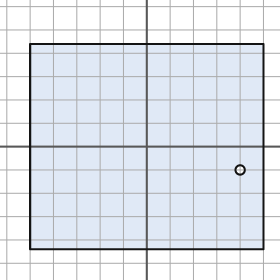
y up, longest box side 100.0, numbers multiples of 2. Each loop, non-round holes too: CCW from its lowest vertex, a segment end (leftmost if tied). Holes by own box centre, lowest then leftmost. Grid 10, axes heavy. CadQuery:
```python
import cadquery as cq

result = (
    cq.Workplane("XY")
    .moveTo(-50.0, -44.0)
    .lineTo(50.0, -44.0)
    .lineTo(50.0, 44.0)
    .lineTo(-50.0, 44.0)
    .close()
    .moveTo(40.0, -10.0)
    .circle(2.0)
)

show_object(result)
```